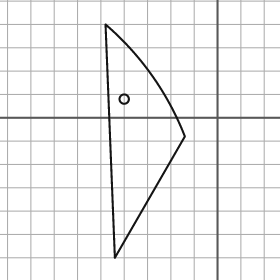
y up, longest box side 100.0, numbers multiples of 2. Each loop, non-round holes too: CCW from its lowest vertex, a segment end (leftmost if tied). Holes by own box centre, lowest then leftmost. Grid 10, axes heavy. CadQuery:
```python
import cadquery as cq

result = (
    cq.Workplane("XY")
    .moveTo(-44.0, -60.0)
    .lineTo(-14.0, -8.0)
    .threePointArc((-28.0, 18.0), (-48.0, 40.0))
    .close()
    .moveTo(-40.0, 8.0)
    .circle(2.0)
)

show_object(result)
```